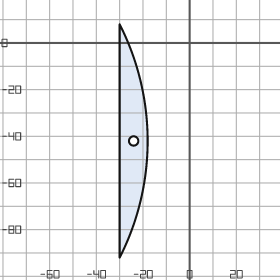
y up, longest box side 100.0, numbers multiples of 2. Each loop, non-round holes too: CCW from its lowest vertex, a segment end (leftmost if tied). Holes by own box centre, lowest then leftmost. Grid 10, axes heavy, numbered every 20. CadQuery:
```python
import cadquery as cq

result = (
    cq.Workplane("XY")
    .moveTo(-30.0, -92.0)
    .threePointArc((-18.0, -42.0), (-30.0, 8.0))
    .close()
    .moveTo(-24.0, -42.0)
    .circle(2.0)
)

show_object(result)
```